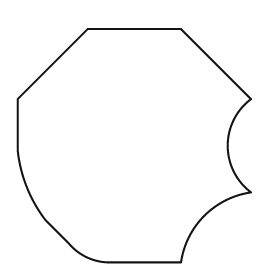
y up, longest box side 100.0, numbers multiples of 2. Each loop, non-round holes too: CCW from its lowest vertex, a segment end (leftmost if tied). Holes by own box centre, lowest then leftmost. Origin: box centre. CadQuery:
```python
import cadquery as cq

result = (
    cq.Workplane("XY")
    .moveTo(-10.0, -50.0)
    .lineTo(20.0, -50.0)
    .threePointArc((30.0, -30.0), (50.0, -20.0))
    .threePointArc((40.0, 0.0), (50.0, 20.0))
    .lineTo(20.0, 50.0)
    .lineTo(-20.0, 50.0)
    .lineTo(-50.0, 20.0)
    .lineTo(-50.0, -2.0)
    .threePointArc((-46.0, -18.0), (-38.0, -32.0))
    .lineTo(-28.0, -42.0)
    .threePointArc((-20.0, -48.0), (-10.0, -50.0))
    .close()
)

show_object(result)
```